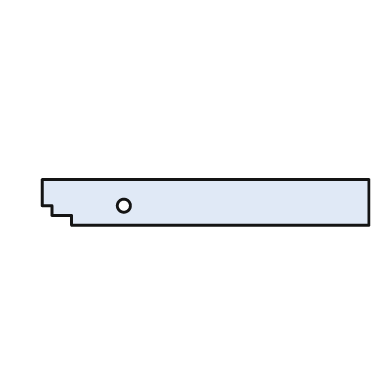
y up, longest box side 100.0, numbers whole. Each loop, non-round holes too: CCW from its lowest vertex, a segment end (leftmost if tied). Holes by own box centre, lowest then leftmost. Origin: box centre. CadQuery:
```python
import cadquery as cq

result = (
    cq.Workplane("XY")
    .moveTo(-41.0, -7.0)
    .lineTo(50.0, -7.0)
    .lineTo(50.0, 7.0)
    .lineTo(-50.0, 7.0)
    .lineTo(-50.0, -1.0)
    .lineTo(-47.0, -1.0)
    .lineTo(-47.0, -4.0)
    .lineTo(-41.0, -4.0)
    .close()
    .moveTo(-25.0, -1.0)
    .circle(2.0)
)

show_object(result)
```